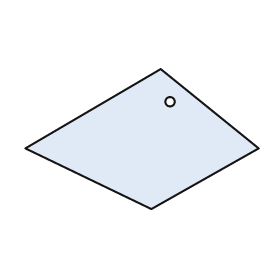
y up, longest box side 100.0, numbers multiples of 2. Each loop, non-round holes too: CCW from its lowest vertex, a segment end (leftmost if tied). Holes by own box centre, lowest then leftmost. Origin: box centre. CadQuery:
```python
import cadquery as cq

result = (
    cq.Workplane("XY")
    .moveTo(4.0, -30.0)
    .lineTo(50.0, -4.0)
    .lineTo(8.0, 30.0)
    .lineTo(-50.0, -4.0)
    .close()
    .moveTo(12.0, 16.0)
    .circle(2.0)
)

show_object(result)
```